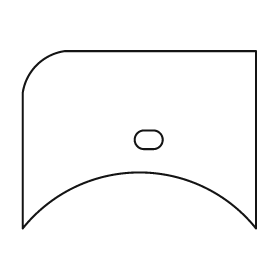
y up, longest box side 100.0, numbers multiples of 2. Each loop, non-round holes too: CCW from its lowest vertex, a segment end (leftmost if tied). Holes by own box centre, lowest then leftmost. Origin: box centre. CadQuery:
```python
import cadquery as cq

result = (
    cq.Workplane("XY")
    .moveTo(-50.0, -38.0)
    .threePointArc((0.0, -14.0), (50.0, -38.0))
    .lineTo(50.0, 38.0)
    .lineTo(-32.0, 38.0)
    .threePointArc((-44.0, 32.0), (-50.0, 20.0))
    .close()
    .moveTo(2.0, -4.0)
    .lineTo(6.0, -4.0)
    .threePointArc((10.0, 0.0), (6.0, 4.0))
    .lineTo(2.0, 4.0)
    .threePointArc((-2.0, 0.0), (2.0, -4.0))
    .close()
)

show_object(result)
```